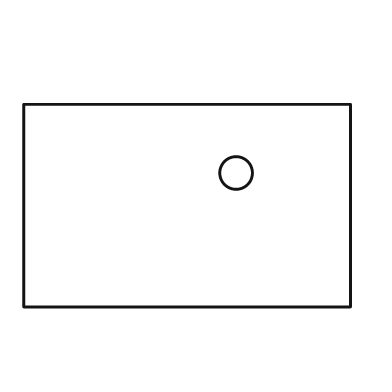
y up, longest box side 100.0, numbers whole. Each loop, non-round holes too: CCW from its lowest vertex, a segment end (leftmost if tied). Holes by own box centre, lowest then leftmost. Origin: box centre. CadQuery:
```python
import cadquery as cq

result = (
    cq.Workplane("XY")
    .moveTo(-50.0, -31.0)
    .lineTo(50.0, -31.0)
    .lineTo(50.0, 31.0)
    .lineTo(-50.0, 31.0)
    .close()
    .moveTo(15.0, 10.0)
    .circle(5.0)
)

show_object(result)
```